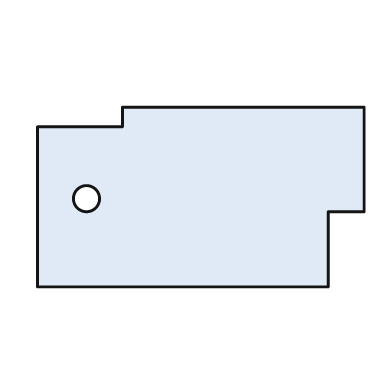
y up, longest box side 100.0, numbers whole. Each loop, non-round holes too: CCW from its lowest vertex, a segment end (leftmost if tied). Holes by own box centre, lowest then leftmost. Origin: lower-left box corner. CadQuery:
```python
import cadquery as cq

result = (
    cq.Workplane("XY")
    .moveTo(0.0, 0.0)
    .lineTo(89.0, 0.0)
    .lineTo(89.0, 23.0)
    .lineTo(100.0, 23.0)
    .lineTo(100.0, 55.0)
    .lineTo(26.0, 55.0)
    .lineTo(26.0, 49.0)
    .lineTo(0.0, 49.0)
    .close()
    .moveTo(15.0, 27.0)
    .circle(4.0)
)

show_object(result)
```